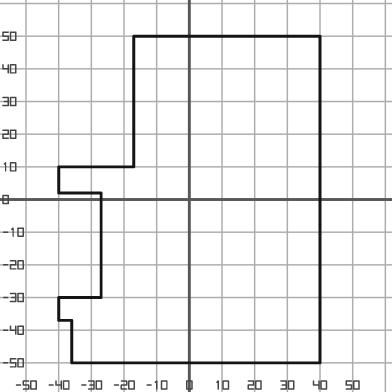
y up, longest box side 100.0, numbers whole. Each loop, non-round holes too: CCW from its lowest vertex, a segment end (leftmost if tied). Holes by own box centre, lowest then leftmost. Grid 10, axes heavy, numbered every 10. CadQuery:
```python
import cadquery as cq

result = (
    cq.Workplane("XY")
    .moveTo(-36.0, -50.0)
    .lineTo(40.0, -50.0)
    .lineTo(40.0, 50.0)
    .lineTo(-17.0, 50.0)
    .lineTo(-17.0, 10.0)
    .lineTo(-40.0, 10.0)
    .lineTo(-40.0, 2.0)
    .lineTo(-27.0, 2.0)
    .lineTo(-27.0, -30.0)
    .lineTo(-40.0, -30.0)
    .lineTo(-40.0, -37.0)
    .lineTo(-36.0, -37.0)
    .close()
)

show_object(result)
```